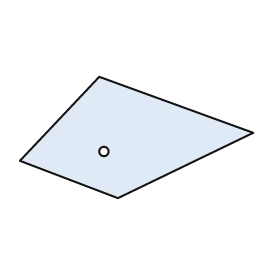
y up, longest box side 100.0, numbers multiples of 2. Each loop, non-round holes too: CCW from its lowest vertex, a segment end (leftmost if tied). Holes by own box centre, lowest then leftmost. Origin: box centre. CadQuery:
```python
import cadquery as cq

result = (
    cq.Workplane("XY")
    .moveTo(-8.0, -26.0)
    .lineTo(50.0, 2.0)
    .lineTo(-16.0, 26.0)
    .lineTo(-50.0, -10.0)
    .close()
    .moveTo(-14.0, -6.0)
    .circle(2.0)
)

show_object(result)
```